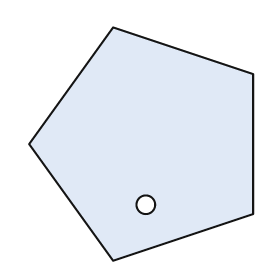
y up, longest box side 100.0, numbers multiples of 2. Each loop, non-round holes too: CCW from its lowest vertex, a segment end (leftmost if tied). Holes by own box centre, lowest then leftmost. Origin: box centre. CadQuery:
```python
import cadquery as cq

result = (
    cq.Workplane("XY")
    .moveTo(-12.0, -50.0)
    .lineTo(48.0, -30.0)
    .lineTo(48.0, 30.0)
    .lineTo(-12.0, 50.0)
    .lineTo(-48.0, 0.0)
    .close()
    .moveTo(2.0, -26.0)
    .circle(4.0)
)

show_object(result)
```